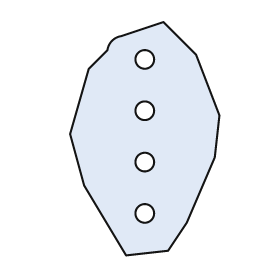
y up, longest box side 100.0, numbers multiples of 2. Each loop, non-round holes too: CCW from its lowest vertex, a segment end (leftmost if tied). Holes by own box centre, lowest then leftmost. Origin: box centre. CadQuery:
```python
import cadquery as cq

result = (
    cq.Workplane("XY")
    .moveTo(-8.0, -50.0)
    .lineTo(10.0, -48.0)
    .lineTo(18.0, -36.0)
    .lineTo(30.0, -8.0)
    .lineTo(32.0, 10.0)
    .lineTo(22.0, 36.0)
    .lineTo(8.0, 50.0)
    .lineTo(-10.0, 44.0)
    .threePointArc((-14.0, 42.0), (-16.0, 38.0))
    .lineTo(-24.0, 30.0)
    .lineTo(-32.0, 2.0)
    .lineTo(-26.0, -20.0)
    .close()
    .moveTo(0.0, -32.0)
    .circle(4.0)
    .moveTo(0.0, -10.0)
    .circle(4.0)
    .moveTo(0.0, 12.0)
    .circle(4.0)
    .moveTo(0.0, 34.0)
    .circle(4.0)
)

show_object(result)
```